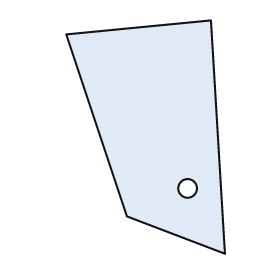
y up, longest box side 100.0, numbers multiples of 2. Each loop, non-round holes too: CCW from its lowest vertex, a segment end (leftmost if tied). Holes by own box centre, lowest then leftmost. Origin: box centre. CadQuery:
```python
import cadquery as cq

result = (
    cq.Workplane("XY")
    .moveTo(34.0, -50.0)
    .lineTo(28.0, 50.0)
    .lineTo(-34.0, 44.0)
    .lineTo(-8.0, -34.0)
    .close()
    .moveTo(18.0, -22.0)
    .circle(4.0)
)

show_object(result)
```